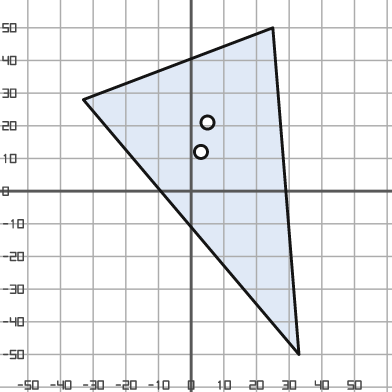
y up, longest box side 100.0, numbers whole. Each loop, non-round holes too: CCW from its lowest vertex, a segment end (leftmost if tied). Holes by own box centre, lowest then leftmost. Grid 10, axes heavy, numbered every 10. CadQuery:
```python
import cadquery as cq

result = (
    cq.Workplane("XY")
    .moveTo(33.0, -50.0)
    .lineTo(25.0, 50.0)
    .lineTo(-33.0, 28.0)
    .close()
    .moveTo(3.0, 12.0)
    .circle(2.0)
    .moveTo(5.0, 21.0)
    .circle(2.0)
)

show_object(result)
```